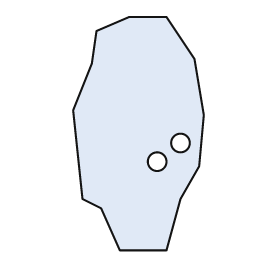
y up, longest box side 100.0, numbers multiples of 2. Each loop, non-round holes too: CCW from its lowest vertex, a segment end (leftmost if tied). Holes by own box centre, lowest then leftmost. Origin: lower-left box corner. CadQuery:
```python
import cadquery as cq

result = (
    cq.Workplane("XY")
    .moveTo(20.0, 0.0)
    .lineTo(40.0, 0.0)
    .lineTo(46.0, 22.0)
    .lineTo(54.0, 36.0)
    .lineTo(56.0, 58.0)
    .lineTo(52.0, 82.0)
    .lineTo(40.0, 100.0)
    .lineTo(24.0, 100.0)
    .lineTo(10.0, 94.0)
    .lineTo(8.0, 80.0)
    .lineTo(0.0, 60.0)
    .lineTo(4.0, 22.0)
    .lineTo(12.0, 18.0)
    .close()
    .moveTo(36.0, 38.0)
    .circle(4.0)
    .moveTo(46.0, 46.0)
    .circle(4.0)
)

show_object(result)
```